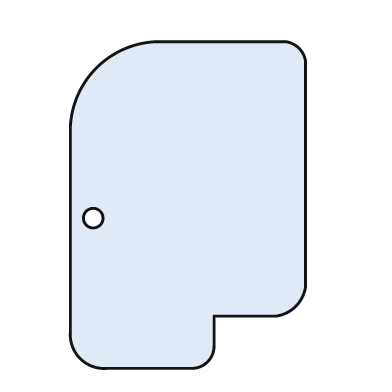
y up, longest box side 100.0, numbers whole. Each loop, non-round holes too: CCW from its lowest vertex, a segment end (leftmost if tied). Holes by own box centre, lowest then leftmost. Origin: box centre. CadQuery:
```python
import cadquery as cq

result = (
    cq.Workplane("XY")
    .moveTo(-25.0, -50.0)
    .lineTo(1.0, -50.0)
    .threePointArc((6.0, -48.0), (8.0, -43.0))
    .lineTo(8.0, -34.0)
    .lineTo(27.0, -34.0)
    .threePointArc((33.0, -31.0), (36.0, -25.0))
    .lineTo(36.0, 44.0)
    .threePointArc((34.0, 48.0), (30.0, 50.0))
    .lineTo(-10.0, 50.0)
    .threePointArc((-28.0, 42.0), (-36.0, 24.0))
    .lineTo(-36.0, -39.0)
    .threePointArc((-33.0, -47.0), (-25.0, -50.0))
    .close()
    .moveTo(-29.0, -4.0)
    .circle(3.0)
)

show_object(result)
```